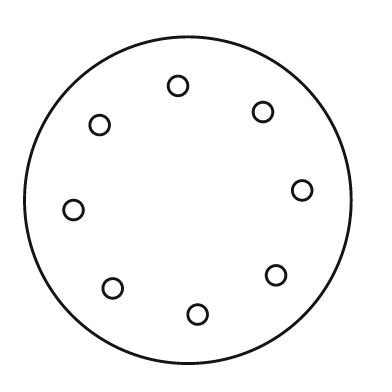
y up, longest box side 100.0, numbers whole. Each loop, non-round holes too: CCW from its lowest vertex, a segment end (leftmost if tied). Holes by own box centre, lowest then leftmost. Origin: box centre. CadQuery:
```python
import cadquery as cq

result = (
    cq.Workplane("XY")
    .moveTo(0.0, 0.0)
    .circle(50.0)
    .moveTo(3.0, -35.0)
    .circle(3.0)
    .moveTo(-23.0, -27.0)
    .circle(3.0)
    .moveTo(27.0, -23.0)
    .circle(3.0)
    .moveTo(-35.0, -3.0)
    .circle(3.0)
    .moveTo(35.0, 3.0)
    .circle(3.0)
    .moveTo(-27.0, 23.0)
    .circle(3.0)
    .moveTo(23.0, 27.0)
    .circle(3.0)
    .moveTo(-3.0, 35.0)
    .circle(3.0)
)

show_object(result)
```